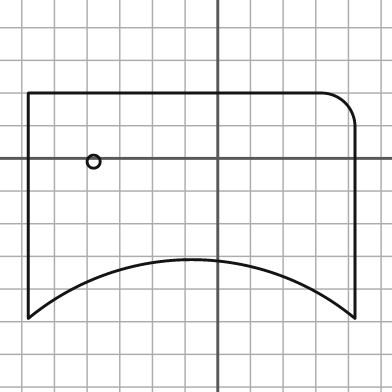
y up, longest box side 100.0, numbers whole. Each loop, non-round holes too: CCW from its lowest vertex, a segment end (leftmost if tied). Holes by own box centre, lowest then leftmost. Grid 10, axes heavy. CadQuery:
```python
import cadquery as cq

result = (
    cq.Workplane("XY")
    .moveTo(-58.0, -49.0)
    .threePointArc((-8.0, -31.0), (42.0, -49.0))
    .lineTo(42.0, 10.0)
    .threePointArc((39.0, 17.0), (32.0, 20.0))
    .lineTo(-58.0, 20.0)
    .close()
    .moveTo(-38.0, -1.0)
    .circle(2.0)
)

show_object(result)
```